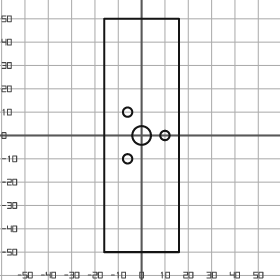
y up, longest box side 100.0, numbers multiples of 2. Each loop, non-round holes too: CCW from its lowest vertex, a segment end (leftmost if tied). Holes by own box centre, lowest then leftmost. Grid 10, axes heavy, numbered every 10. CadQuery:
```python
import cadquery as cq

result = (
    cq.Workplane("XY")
    .moveTo(-16.0, -50.0)
    .lineTo(16.0, -50.0)
    .lineTo(16.0, 50.0)
    .lineTo(-16.0, 50.0)
    .close()
    .moveTo(-6.0, -10.0)
    .circle(2.0)
    .moveTo(0.0, 0.0)
    .circle(4.0)
    .moveTo(10.0, 0.0)
    .circle(2.0)
    .moveTo(-6.0, 10.0)
    .circle(2.0)
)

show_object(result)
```